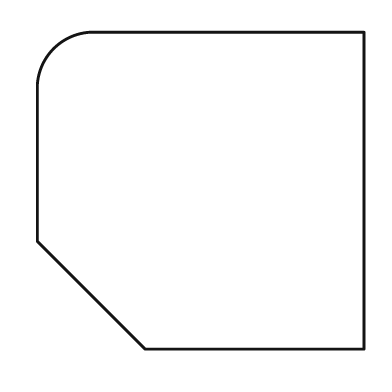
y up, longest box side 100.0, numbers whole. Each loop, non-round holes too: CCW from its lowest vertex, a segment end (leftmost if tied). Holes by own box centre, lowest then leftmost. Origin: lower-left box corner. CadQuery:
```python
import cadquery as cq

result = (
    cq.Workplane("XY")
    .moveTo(33.0, 0.0)
    .lineTo(100.0, 0.0)
    .lineTo(100.0, 97.0)
    .lineTo(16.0, 97.0)
    .threePointArc((5.0, 92.0), (0.0, 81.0))
    .lineTo(0.0, 33.0)
    .close()
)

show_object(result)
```